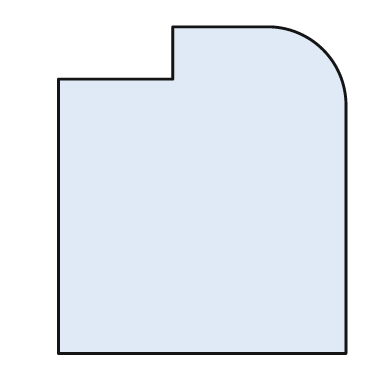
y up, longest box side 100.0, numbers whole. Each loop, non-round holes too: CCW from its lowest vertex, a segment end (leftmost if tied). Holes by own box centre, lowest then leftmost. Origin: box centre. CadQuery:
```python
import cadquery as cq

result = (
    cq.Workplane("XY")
    .moveTo(-44.0, -50.0)
    .lineTo(44.0, -50.0)
    .lineTo(44.0, 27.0)
    .threePointArc((37.0, 43.0), (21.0, 50.0))
    .lineTo(-9.0, 50.0)
    .lineTo(-9.0, 34.0)
    .lineTo(-44.0, 34.0)
    .close()
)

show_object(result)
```